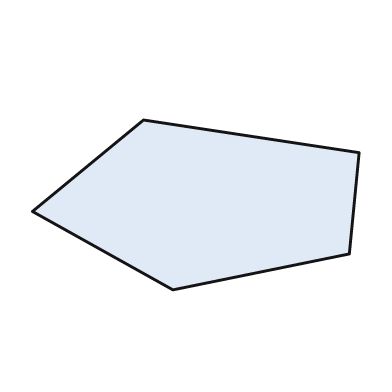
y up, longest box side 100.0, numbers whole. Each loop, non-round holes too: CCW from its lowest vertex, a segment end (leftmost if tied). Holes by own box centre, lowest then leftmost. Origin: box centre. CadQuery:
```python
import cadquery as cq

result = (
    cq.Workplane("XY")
    .moveTo(-7.0, -26.0)
    .lineTo(47.0, -15.0)
    .lineTo(50.0, 16.0)
    .lineTo(-16.0, 26.0)
    .lineTo(-50.0, -2.0)
    .close()
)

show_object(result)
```